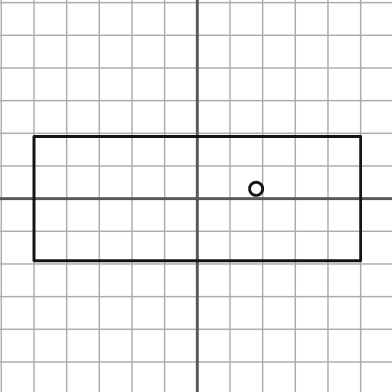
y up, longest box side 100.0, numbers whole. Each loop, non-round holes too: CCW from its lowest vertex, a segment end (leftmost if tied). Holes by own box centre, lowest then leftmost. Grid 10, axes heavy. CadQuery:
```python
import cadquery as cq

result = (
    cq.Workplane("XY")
    .moveTo(-50.0, -19.0)
    .lineTo(50.0, -19.0)
    .lineTo(50.0, 19.0)
    .lineTo(-50.0, 19.0)
    .close()
    .moveTo(18.0, 3.0)
    .circle(2.0)
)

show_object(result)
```